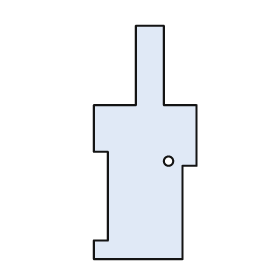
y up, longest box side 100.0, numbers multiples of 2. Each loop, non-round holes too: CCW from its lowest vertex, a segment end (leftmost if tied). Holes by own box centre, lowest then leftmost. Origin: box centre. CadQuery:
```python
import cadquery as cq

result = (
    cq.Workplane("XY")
    .moveTo(-22.0, -50.0)
    .lineTo(16.0, -50.0)
    .lineTo(16.0, -10.0)
    .lineTo(22.0, -10.0)
    .lineTo(22.0, 16.0)
    .lineTo(8.0, 16.0)
    .lineTo(8.0, 50.0)
    .lineTo(-4.0, 50.0)
    .lineTo(-4.0, 16.0)
    .lineTo(-22.0, 16.0)
    .lineTo(-22.0, -4.0)
    .lineTo(-16.0, -4.0)
    .lineTo(-16.0, -42.0)
    .lineTo(-22.0, -42.0)
    .close()
    .moveTo(10.0, -8.0)
    .circle(2.0)
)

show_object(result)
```